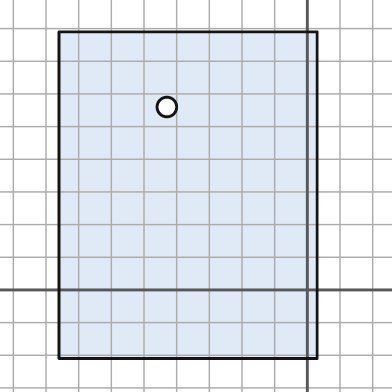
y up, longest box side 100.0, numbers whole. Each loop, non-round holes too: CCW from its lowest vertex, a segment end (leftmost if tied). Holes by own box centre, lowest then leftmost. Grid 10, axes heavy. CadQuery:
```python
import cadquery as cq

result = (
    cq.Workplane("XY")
    .moveTo(-76.0, -21.0)
    .lineTo(3.0, -21.0)
    .lineTo(3.0, 79.0)
    .lineTo(-76.0, 79.0)
    .close()
    .moveTo(-43.0, 56.0)
    .circle(3.0)
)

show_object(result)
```